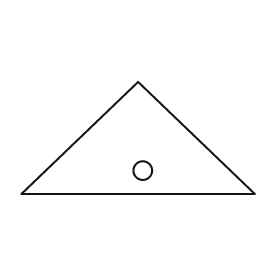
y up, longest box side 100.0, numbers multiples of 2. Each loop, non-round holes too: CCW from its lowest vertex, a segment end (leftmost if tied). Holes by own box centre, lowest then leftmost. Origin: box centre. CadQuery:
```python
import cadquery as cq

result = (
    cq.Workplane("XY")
    .moveTo(-50.0, -24.0)
    .lineTo(50.0, -24.0)
    .lineTo(0.0, 24.0)
    .close()
    .moveTo(2.0, -14.0)
    .circle(4.0)
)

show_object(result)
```